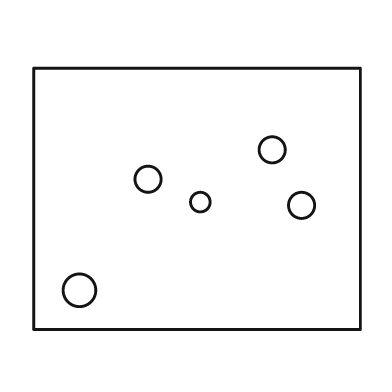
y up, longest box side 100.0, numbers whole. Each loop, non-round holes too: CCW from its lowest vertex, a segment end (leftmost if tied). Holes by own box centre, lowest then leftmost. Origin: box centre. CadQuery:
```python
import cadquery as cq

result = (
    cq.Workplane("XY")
    .moveTo(-50.0, -40.0)
    .lineTo(50.0, -40.0)
    .lineTo(50.0, 40.0)
    .lineTo(-50.0, 40.0)
    .close()
    .moveTo(-36.0, -28.0)
    .circle(5.0)
    .moveTo(32.0, -2.0)
    .circle(4.0)
    .moveTo(1.0, -1.0)
    .circle(3.0)
    .moveTo(-15.0, 6.0)
    .circle(4.0)
    .moveTo(23.0, 15.0)
    .circle(4.0)
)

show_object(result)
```